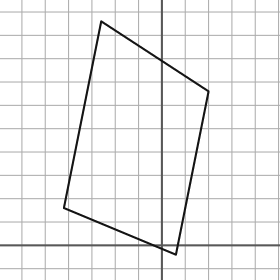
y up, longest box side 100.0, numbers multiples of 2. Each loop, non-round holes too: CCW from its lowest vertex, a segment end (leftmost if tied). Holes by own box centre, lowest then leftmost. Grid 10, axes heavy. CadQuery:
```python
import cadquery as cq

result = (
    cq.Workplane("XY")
    .moveTo(6.0, -4.0)
    .lineTo(20.0, 66.0)
    .lineTo(-26.0, 96.0)
    .lineTo(-42.0, 16.0)
    .close()
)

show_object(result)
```